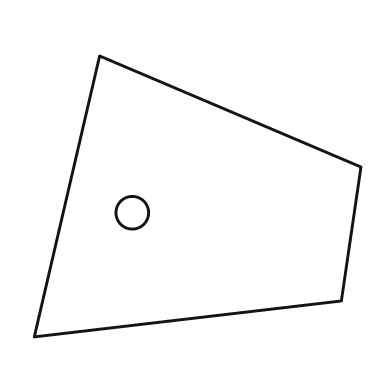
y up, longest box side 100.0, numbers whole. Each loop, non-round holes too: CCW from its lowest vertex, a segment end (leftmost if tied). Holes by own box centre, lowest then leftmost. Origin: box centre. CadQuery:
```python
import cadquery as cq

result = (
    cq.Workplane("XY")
    .moveTo(-50.0, -43.0)
    .lineTo(44.0, -32.0)
    .lineTo(50.0, 9.0)
    .lineTo(-30.0, 43.0)
    .close()
    .moveTo(-20.0, -5.0)
    .circle(5.0)
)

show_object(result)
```